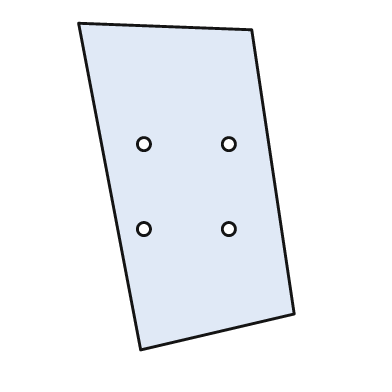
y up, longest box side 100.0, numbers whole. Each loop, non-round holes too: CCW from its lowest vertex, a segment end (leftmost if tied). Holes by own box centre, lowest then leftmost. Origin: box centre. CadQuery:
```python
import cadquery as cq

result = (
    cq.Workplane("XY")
    .moveTo(-14.0, -50.0)
    .lineTo(33.0, -39.0)
    .lineTo(20.0, 48.0)
    .lineTo(-33.0, 50.0)
    .close()
    .moveTo(-13.0, -13.0)
    .circle(2.0)
    .moveTo(13.0, -13.0)
    .circle(2.0)
    .moveTo(-13.0, 13.0)
    .circle(2.0)
    .moveTo(13.0, 13.0)
    .circle(2.0)
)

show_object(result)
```